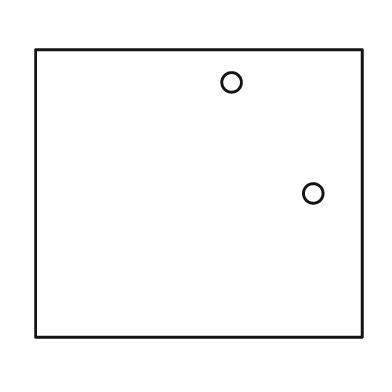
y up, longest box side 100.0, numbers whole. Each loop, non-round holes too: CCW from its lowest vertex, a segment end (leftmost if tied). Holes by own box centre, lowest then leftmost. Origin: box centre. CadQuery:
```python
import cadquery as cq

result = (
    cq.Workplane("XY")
    .moveTo(-50.0, -44.0)
    .lineTo(50.0, -44.0)
    .lineTo(50.0, 44.0)
    .lineTo(-50.0, 44.0)
    .close()
    .moveTo(35.0, 0.0)
    .circle(3.0)
    .moveTo(10.0, 34.0)
    .circle(3.0)
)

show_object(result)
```